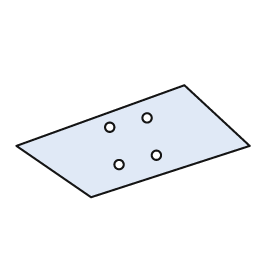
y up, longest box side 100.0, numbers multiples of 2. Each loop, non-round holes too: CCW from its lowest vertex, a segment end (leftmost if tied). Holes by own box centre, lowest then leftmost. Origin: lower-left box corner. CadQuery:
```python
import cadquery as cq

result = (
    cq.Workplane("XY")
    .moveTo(32.0, 0.0)
    .lineTo(100.0, 22.0)
    .lineTo(72.0, 48.0)
    .lineTo(0.0, 22.0)
    .close()
    .moveTo(44.0, 14.0)
    .circle(2.0)
    .moveTo(60.0, 18.0)
    .circle(2.0)
    .moveTo(40.0, 30.0)
    .circle(2.0)
    .moveTo(56.0, 34.0)
    .circle(2.0)
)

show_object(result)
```